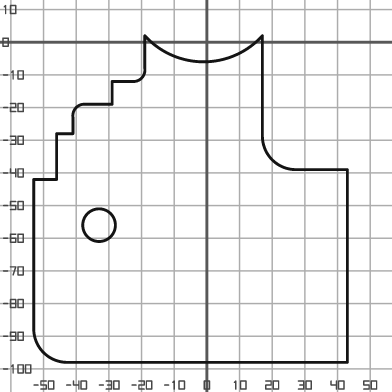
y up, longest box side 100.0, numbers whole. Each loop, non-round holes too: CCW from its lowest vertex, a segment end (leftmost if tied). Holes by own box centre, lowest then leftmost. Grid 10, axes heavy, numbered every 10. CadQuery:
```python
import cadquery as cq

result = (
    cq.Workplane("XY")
    .moveTo(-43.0, -98.0)
    .lineTo(43.0, -98.0)
    .lineTo(43.0, -39.0)
    .lineTo(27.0, -39.0)
    .threePointArc((20.0, -36.0), (17.0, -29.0))
    .lineTo(17.0, 2.0)
    .threePointArc((-1.0, -6.0), (-19.0, 2.0))
    .lineTo(-19.0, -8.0)
    .threePointArc((-20.0, -11.0), (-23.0, -12.0))
    .lineTo(-29.0, -12.0)
    .lineTo(-29.0, -19.0)
    .lineTo(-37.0, -19.0)
    .threePointArc((-40.0, -20.0), (-41.0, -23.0))
    .lineTo(-41.0, -28.0)
    .lineTo(-46.0, -28.0)
    .lineTo(-46.0, -42.0)
    .lineTo(-53.0, -42.0)
    .lineTo(-53.0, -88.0)
    .threePointArc((-50.0, -95.0), (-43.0, -98.0))
    .close()
    .moveTo(-33.0, -56.0)
    .circle(5.0)
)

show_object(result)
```